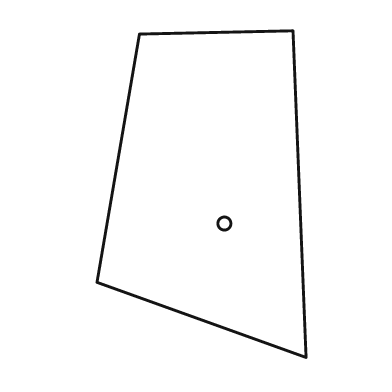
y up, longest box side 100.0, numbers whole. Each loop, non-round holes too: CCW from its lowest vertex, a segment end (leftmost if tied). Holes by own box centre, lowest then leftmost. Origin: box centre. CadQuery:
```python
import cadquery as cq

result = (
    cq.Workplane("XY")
    .moveTo(32.0, -50.0)
    .lineTo(28.0, 50.0)
    .lineTo(-19.0, 49.0)
    .lineTo(-32.0, -27.0)
    .close()
    .moveTo(7.0, -9.0)
    .circle(2.0)
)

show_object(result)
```